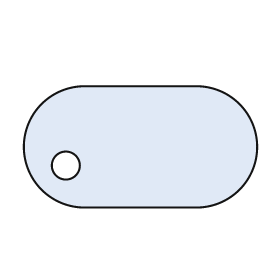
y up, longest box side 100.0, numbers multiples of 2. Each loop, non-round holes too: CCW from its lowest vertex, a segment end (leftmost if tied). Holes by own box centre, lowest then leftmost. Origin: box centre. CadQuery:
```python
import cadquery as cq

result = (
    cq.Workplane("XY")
    .moveTo(-24.0, -26.0)
    .lineTo(24.0, -26.0)
    .threePointArc((50.0, 0.0), (24.0, 26.0))
    .lineTo(-24.0, 26.0)
    .threePointArc((-50.0, 0.0), (-24.0, -26.0))
    .close()
    .moveTo(-32.0, -8.0)
    .circle(6.0)
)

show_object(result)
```